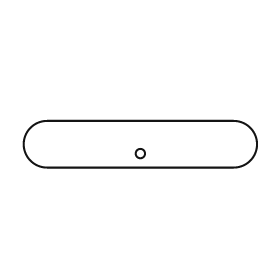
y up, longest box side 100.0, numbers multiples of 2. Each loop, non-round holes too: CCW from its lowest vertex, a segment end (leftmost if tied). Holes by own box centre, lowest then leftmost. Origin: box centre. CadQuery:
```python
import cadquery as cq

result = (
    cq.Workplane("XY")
    .moveTo(-40.0, -10.0)
    .lineTo(40.0, -10.0)
    .threePointArc((50.0, 0.0), (40.0, 10.0))
    .lineTo(-40.0, 10.0)
    .threePointArc((-50.0, 0.0), (-40.0, -10.0))
    .close()
    .moveTo(0.0, -4.0)
    .circle(2.0)
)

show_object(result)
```